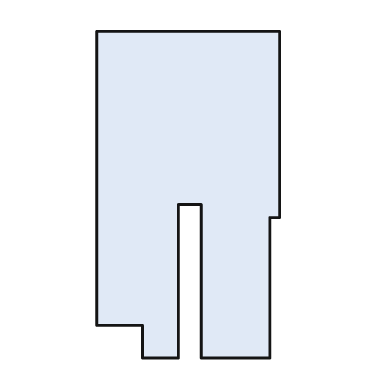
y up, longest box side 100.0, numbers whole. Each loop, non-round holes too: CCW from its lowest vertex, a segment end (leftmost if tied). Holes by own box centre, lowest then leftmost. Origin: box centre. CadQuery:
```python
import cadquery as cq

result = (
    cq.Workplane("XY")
    .moveTo(-14.0, -50.0)
    .lineTo(-3.0, -50.0)
    .lineTo(-3.0, -3.0)
    .lineTo(4.0, -3.0)
    .lineTo(4.0, -50.0)
    .lineTo(25.0, -50.0)
    .lineTo(25.0, -7.0)
    .lineTo(28.0, -7.0)
    .lineTo(28.0, 50.0)
    .lineTo(-28.0, 50.0)
    .lineTo(-28.0, -40.0)
    .lineTo(-14.0, -40.0)
    .close()
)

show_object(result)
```